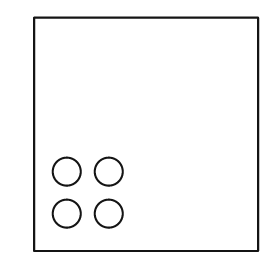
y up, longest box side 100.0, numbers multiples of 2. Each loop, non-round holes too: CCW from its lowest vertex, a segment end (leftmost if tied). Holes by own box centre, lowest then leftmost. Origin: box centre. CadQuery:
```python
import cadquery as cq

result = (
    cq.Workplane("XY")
    .moveTo(-48.0, -50.0)
    .lineTo(48.0, -50.0)
    .lineTo(48.0, 50.0)
    .lineTo(-48.0, 50.0)
    .close()
    .moveTo(-34.0, -34.0)
    .circle(6.0)
    .moveTo(-16.0, -34.0)
    .circle(6.0)
    .moveTo(-34.0, -16.0)
    .circle(6.0)
    .moveTo(-16.0, -16.0)
    .circle(6.0)
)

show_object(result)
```